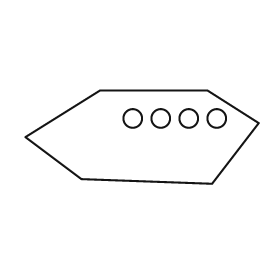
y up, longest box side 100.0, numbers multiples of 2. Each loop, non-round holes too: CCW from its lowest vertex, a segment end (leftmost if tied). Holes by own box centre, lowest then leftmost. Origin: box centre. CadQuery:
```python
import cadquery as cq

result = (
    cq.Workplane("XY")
    .moveTo(30.0, -20.0)
    .lineTo(50.0, 6.0)
    .lineTo(28.0, 20.0)
    .lineTo(-18.0, 20.0)
    .lineTo(-50.0, 0.0)
    .lineTo(-26.0, -18.0)
    .close()
    .moveTo(-4.0, 8.0)
    .circle(4.0)
    .moveTo(8.0, 8.0)
    .circle(4.0)
    .moveTo(20.0, 8.0)
    .circle(4.0)
    .moveTo(32.0, 8.0)
    .circle(4.0)
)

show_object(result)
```